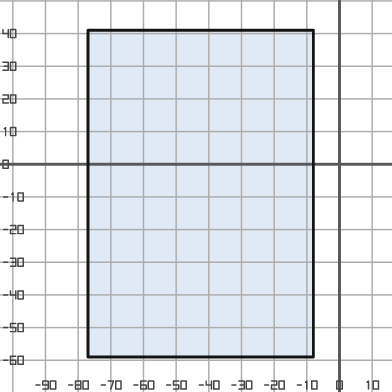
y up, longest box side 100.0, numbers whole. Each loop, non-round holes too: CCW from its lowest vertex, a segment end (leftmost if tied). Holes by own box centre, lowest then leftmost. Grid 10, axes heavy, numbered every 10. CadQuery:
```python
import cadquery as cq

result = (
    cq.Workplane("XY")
    .moveTo(-77.0, -59.0)
    .lineTo(-8.0, -59.0)
    .lineTo(-8.0, 41.0)
    .lineTo(-77.0, 41.0)
    .close()
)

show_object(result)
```